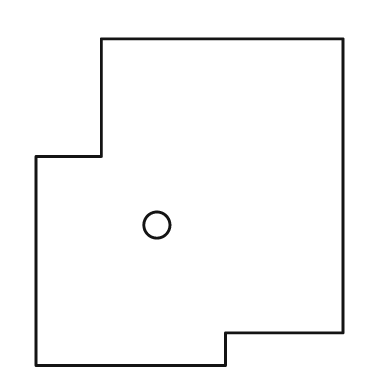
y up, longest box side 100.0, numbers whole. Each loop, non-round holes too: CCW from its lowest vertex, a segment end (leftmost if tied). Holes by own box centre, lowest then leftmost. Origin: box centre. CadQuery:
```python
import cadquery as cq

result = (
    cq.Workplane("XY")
    .moveTo(-47.0, -50.0)
    .lineTo(11.0, -50.0)
    .lineTo(11.0, -40.0)
    .lineTo(47.0, -40.0)
    .lineTo(47.0, 50.0)
    .lineTo(-27.0, 50.0)
    .lineTo(-27.0, 14.0)
    .lineTo(-47.0, 14.0)
    .close()
    .moveTo(-10.0, -7.0)
    .circle(4.0)
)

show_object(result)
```